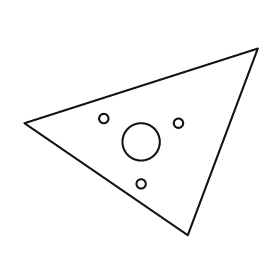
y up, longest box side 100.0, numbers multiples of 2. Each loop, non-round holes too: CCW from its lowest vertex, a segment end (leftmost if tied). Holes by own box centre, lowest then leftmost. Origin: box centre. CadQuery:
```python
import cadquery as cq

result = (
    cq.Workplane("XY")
    .moveTo(20.0, -40.0)
    .lineTo(50.0, 40.0)
    .lineTo(-50.0, 8.0)
    .close()
    .moveTo(0.0, -18.0)
    .circle(2.0)
    .moveTo(0.0, 0.0)
    .circle(8.0)
    .moveTo(16.0, 8.0)
    .circle(2.0)
    .moveTo(-16.0, 10.0)
    .circle(2.0)
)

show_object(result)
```